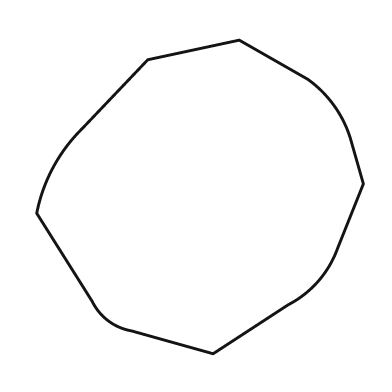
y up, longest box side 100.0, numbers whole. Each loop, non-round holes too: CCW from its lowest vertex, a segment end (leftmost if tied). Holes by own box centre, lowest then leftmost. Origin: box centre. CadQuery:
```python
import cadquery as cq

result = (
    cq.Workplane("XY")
    .moveTo(4.0, -48.0)
    .lineTo(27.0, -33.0)
    .threePointArc((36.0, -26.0), (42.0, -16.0))
    .lineTo(50.0, 4.0)
    .lineTo(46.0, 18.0)
    .threePointArc((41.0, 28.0), (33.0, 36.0))
    .lineTo(12.0, 48.0)
    .lineTo(-16.0, 42.0)
    .lineTo(-36.0, 21.0)
    .threePointArc((-45.0, 9.0), (-50.0, -5.0))
    .lineTo(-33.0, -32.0)
    .threePointArc((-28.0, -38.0), (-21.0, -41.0))
    .close()
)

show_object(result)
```